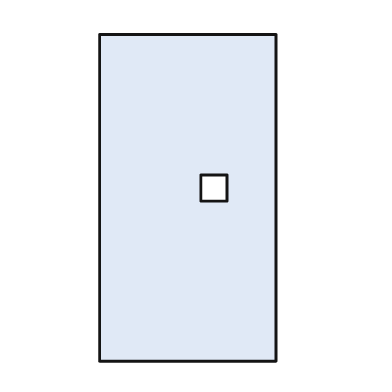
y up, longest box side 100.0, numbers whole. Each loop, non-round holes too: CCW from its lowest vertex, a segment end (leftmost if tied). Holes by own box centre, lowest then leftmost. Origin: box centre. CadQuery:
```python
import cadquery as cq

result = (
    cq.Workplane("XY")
    .moveTo(-27.0, -50.0)
    .lineTo(27.0, -50.0)
    .lineTo(27.0, 50.0)
    .lineTo(-27.0, 50.0)
    .close()
    .moveTo(4.0, -1.0)
    .lineTo(12.0, -1.0)
    .lineTo(12.0, 7.0)
    .lineTo(4.0, 7.0)
    .close()
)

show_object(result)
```